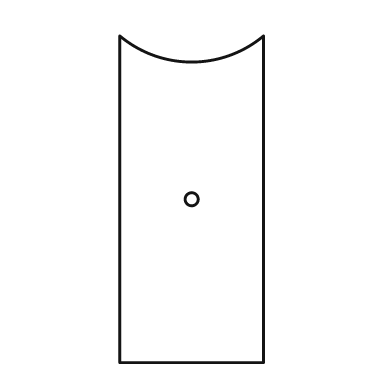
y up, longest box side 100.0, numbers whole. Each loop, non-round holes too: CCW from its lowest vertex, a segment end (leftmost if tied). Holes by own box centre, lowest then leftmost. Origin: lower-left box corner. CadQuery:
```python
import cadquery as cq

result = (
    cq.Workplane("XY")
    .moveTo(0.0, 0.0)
    .lineTo(44.0, 0.0)
    .lineTo(44.0, 100.0)
    .threePointArc((22.0, 92.0), (0.0, 100.0))
    .close()
    .moveTo(22.0, 50.0)
    .circle(2.0)
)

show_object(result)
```